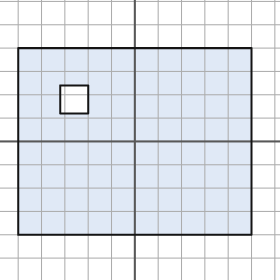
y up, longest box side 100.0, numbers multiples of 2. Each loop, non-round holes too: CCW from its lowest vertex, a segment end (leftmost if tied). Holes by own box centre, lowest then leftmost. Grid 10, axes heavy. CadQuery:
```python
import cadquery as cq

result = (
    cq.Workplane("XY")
    .moveTo(-50.0, -40.0)
    .lineTo(50.0, -40.0)
    .lineTo(50.0, 40.0)
    .lineTo(-50.0, 40.0)
    .close()
    .moveTo(-32.0, 12.0)
    .lineTo(-20.0, 12.0)
    .lineTo(-20.0, 24.0)
    .lineTo(-32.0, 24.0)
    .close()
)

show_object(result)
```